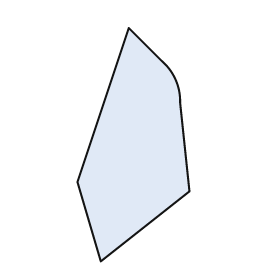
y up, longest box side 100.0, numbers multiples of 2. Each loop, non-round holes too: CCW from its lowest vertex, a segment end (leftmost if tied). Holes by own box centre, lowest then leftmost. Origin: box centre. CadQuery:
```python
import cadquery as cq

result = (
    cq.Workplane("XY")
    .moveTo(-14.0, -50.0)
    .lineTo(24.0, -20.0)
    .lineTo(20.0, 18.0)
    .threePointArc((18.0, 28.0), (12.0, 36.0))
    .lineTo(-2.0, 50.0)
    .lineTo(-24.0, -16.0)
    .close()
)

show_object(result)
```